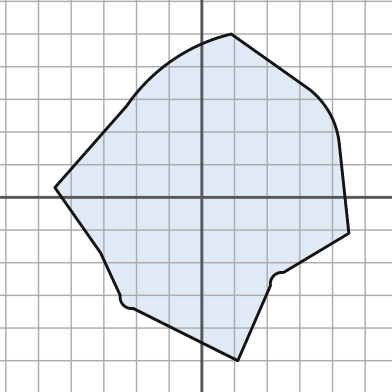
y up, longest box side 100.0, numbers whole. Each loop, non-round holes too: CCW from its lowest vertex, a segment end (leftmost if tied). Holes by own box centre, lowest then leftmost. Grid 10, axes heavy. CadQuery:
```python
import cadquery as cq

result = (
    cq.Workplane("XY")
    .moveTo(11.0, -50.0)
    .lineTo(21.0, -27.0)
    .threePointArc((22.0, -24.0), (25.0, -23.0))
    .lineTo(45.0, -11.0)
    .lineTo(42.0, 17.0)
    .threePointArc((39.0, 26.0), (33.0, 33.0))
    .lineTo(9.0, 50.0)
    .threePointArc((-9.0, 42.0), (-23.0, 28.0))
    .lineTo(-45.0, 3.0)
    .lineTo(-31.0, -17.0)
    .lineTo(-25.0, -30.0)
    .threePointArc((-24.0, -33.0), (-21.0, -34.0))
    .close()
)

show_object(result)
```